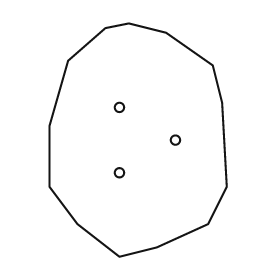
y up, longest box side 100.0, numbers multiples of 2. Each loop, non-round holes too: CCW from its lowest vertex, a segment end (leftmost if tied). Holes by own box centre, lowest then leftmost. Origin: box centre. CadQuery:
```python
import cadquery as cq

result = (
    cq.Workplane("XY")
    .moveTo(-8.0, -50.0)
    .lineTo(8.0, -46.0)
    .lineTo(30.0, -36.0)
    .lineTo(38.0, -20.0)
    .lineTo(36.0, 16.0)
    .lineTo(32.0, 32.0)
    .lineTo(12.0, 46.0)
    .lineTo(-4.0, 50.0)
    .lineTo(-14.0, 48.0)
    .lineTo(-30.0, 34.0)
    .lineTo(-38.0, 6.0)
    .lineTo(-38.0, -20.0)
    .lineTo(-26.0, -36.0)
    .close()
    .moveTo(-8.0, -14.0)
    .circle(2.0)
    .moveTo(16.0, 0.0)
    .circle(2.0)
    .moveTo(-8.0, 14.0)
    .circle(2.0)
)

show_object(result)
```